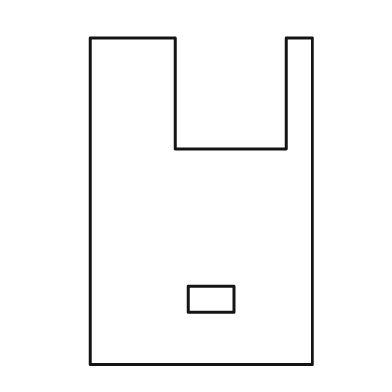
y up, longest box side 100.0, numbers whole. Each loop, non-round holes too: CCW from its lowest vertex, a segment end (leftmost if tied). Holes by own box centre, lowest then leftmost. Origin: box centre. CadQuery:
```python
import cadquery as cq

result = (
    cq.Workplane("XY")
    .moveTo(-34.0, -50.0)
    .lineTo(34.0, -50.0)
    .lineTo(34.0, 50.0)
    .lineTo(26.0, 50.0)
    .lineTo(26.0, 16.0)
    .lineTo(-8.0, 16.0)
    .lineTo(-8.0, 50.0)
    .lineTo(-34.0, 50.0)
    .close()
    .moveTo(-4.0, -34.0)
    .lineTo(10.0, -34.0)
    .lineTo(10.0, -26.0)
    .lineTo(-4.0, -26.0)
    .close()
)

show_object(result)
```